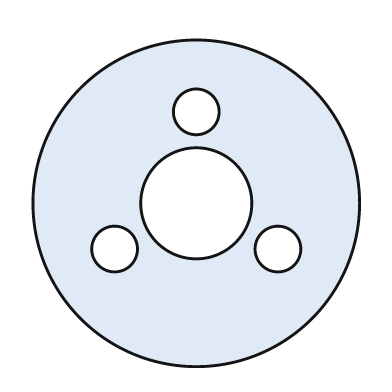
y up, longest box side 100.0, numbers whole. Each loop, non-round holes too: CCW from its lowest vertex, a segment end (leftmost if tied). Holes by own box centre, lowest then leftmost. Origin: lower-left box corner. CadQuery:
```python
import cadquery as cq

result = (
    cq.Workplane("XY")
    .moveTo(50.0, 50.0)
    .circle(50.0)
    .moveTo(25.0, 36.0)
    .circle(7.0)
    .moveTo(75.0, 36.0)
    .circle(7.0)
    .moveTo(50.0, 50.0)
    .circle(17.0)
    .moveTo(50.0, 78.0)
    .circle(7.0)
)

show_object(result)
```